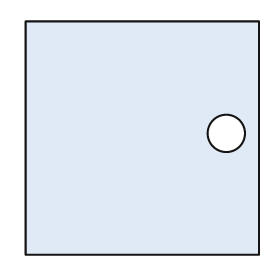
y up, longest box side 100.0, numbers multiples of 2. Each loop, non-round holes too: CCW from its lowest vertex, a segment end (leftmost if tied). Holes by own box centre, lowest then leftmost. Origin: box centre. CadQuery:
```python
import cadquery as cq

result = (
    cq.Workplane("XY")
    .moveTo(-50.0, -50.0)
    .lineTo(50.0, -50.0)
    .lineTo(50.0, 50.0)
    .lineTo(-50.0, 50.0)
    .close()
    .moveTo(36.0, 2.0)
    .circle(8.0)
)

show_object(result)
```